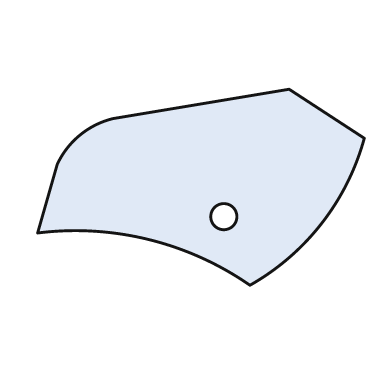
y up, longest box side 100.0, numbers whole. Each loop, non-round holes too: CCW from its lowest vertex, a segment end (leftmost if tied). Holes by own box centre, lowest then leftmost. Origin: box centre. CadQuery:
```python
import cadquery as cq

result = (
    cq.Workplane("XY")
    .moveTo(15.0, -30.0)
    .threePointArc((37.0, -11.0), (50.0, 15.0))
    .lineTo(27.0, 30.0)
    .lineTo(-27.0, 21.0)
    .threePointArc((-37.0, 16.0), (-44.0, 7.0))
    .lineTo(-50.0, -14.0)
    .threePointArc((-16.0, -16.0), (15.0, -30.0))
    .close()
    .moveTo(7.0, -9.0)
    .circle(4.0)
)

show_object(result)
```